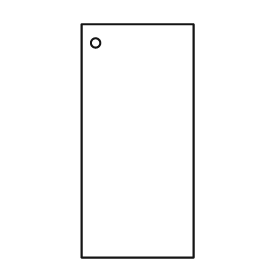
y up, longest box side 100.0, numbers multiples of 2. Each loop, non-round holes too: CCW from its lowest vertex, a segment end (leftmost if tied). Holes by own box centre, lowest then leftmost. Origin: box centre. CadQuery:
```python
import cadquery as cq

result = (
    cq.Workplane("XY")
    .moveTo(-24.0, -50.0)
    .lineTo(24.0, -50.0)
    .lineTo(24.0, 50.0)
    .lineTo(-24.0, 50.0)
    .close()
    .moveTo(-18.0, 42.0)
    .circle(2.0)
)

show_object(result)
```